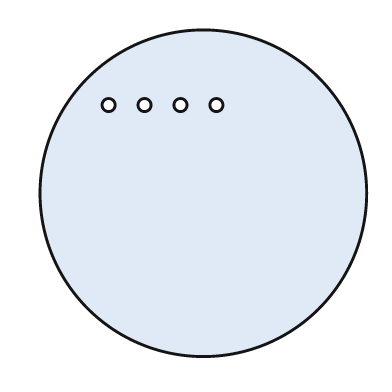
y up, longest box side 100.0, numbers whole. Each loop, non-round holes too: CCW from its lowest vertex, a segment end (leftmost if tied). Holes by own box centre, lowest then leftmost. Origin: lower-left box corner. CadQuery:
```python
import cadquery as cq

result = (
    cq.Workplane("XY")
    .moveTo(50.0, 50.0)
    .circle(50.0)
    .moveTo(21.0, 77.0)
    .circle(2.0)
    .moveTo(32.0, 77.0)
    .circle(2.0)
    .moveTo(43.0, 77.0)
    .circle(2.0)
    .moveTo(54.0, 77.0)
    .circle(2.0)
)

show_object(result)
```